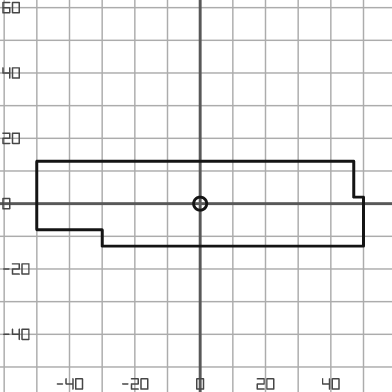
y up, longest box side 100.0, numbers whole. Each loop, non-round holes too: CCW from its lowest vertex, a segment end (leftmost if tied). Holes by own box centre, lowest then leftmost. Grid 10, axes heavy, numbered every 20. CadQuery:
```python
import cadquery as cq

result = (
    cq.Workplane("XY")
    .moveTo(-30.0, -13.0)
    .lineTo(50.0, -13.0)
    .lineTo(50.0, 2.0)
    .lineTo(47.0, 2.0)
    .lineTo(47.0, 13.0)
    .lineTo(-50.0, 13.0)
    .lineTo(-50.0, -8.0)
    .lineTo(-30.0, -8.0)
    .close()
    .moveTo(0.0, 0.0)
    .circle(2.0)
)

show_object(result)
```